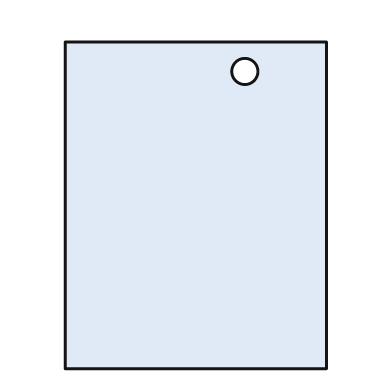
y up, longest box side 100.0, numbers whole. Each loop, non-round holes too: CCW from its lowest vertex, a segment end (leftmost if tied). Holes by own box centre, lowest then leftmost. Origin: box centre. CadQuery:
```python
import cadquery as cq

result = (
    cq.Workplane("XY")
    .moveTo(-40.0, -50.0)
    .lineTo(40.0, -50.0)
    .lineTo(40.0, 50.0)
    .lineTo(-40.0, 50.0)
    .close()
    .moveTo(15.0, 41.0)
    .circle(4.0)
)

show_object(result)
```